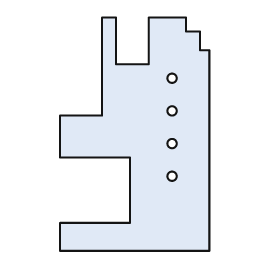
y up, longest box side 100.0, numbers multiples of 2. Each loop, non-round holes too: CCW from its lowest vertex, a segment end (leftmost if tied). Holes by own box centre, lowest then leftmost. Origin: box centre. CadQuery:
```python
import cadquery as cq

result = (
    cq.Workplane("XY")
    .moveTo(-32.0, -50.0)
    .lineTo(32.0, -50.0)
    .lineTo(32.0, 36.0)
    .lineTo(28.0, 36.0)
    .lineTo(28.0, 44.0)
    .lineTo(22.0, 44.0)
    .lineTo(22.0, 50.0)
    .lineTo(6.0, 50.0)
    .lineTo(6.0, 30.0)
    .lineTo(-8.0, 30.0)
    .lineTo(-8.0, 50.0)
    .lineTo(-14.0, 50.0)
    .lineTo(-14.0, 8.0)
    .lineTo(-32.0, 8.0)
    .lineTo(-32.0, -10.0)
    .lineTo(-2.0, -10.0)
    .lineTo(-2.0, -38.0)
    .lineTo(-32.0, -38.0)
    .close()
    .moveTo(16.0, -18.0)
    .circle(2.0)
    .moveTo(16.0, -4.0)
    .circle(2.0)
    .moveTo(16.0, 10.0)
    .circle(2.0)
    .moveTo(16.0, 24.0)
    .circle(2.0)
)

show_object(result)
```